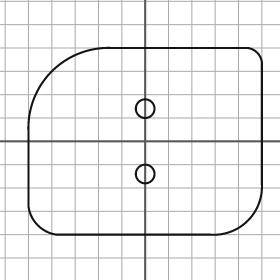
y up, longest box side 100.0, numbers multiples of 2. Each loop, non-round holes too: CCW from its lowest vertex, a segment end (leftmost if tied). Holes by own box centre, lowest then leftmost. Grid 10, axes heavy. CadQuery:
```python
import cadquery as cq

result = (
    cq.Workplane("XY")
    .moveTo(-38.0, -40.0)
    .lineTo(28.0, -40.0)
    .threePointArc((44.0, -34.0), (50.0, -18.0))
    .lineTo(50.0, 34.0)
    .threePointArc((48.0, 38.0), (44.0, 40.0))
    .lineTo(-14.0, 40.0)
    .threePointArc((-40.0, 30.0), (-50.0, 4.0))
    .lineTo(-50.0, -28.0)
    .threePointArc((-46.0, -36.0), (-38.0, -40.0))
    .close()
    .moveTo(0.0, -14.0)
    .circle(4.0)
    .moveTo(0.0, 14.0)
    .circle(4.0)
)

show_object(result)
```